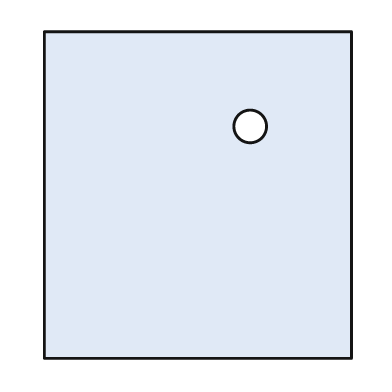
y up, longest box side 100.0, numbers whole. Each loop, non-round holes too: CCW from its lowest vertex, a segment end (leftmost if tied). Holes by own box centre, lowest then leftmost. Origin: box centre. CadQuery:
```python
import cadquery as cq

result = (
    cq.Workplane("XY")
    .moveTo(-47.0, -50.0)
    .lineTo(47.0, -50.0)
    .lineTo(47.0, 50.0)
    .lineTo(-47.0, 50.0)
    .close()
    .moveTo(16.0, 21.0)
    .circle(5.0)
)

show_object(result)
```